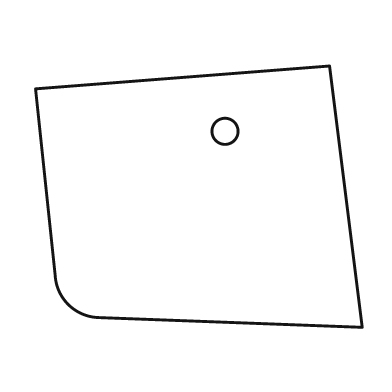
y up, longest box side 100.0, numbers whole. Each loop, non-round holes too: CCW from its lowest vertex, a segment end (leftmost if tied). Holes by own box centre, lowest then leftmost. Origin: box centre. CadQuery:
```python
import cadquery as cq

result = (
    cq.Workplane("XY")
    .moveTo(50.0, -40.0)
    .lineTo(40.0, 40.0)
    .lineTo(-50.0, 33.0)
    .lineTo(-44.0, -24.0)
    .threePointArc((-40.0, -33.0), (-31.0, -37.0))
    .close()
    .moveTo(8.0, 20.0)
    .circle(4.0)
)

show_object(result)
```